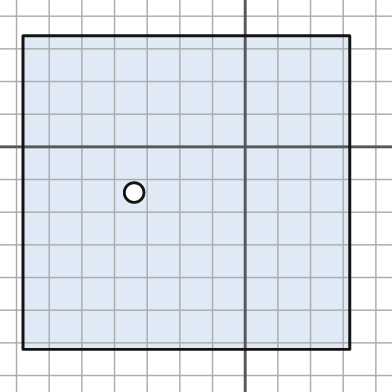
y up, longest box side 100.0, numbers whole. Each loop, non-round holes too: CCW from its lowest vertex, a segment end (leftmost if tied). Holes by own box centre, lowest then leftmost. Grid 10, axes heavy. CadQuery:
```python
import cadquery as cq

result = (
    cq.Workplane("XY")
    .moveTo(-68.0, -62.0)
    .lineTo(32.0, -62.0)
    .lineTo(32.0, 34.0)
    .lineTo(-68.0, 34.0)
    .close()
    .moveTo(-34.0, -14.0)
    .circle(3.0)
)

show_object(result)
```